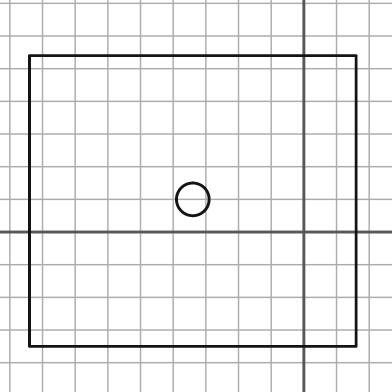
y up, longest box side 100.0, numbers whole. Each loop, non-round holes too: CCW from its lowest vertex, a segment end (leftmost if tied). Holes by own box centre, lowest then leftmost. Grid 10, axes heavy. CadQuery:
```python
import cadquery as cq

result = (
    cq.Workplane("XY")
    .moveTo(-84.0, -35.0)
    .lineTo(16.0, -35.0)
    .lineTo(16.0, 54.0)
    .lineTo(-84.0, 54.0)
    .close()
    .moveTo(-34.0, 10.0)
    .circle(5.0)
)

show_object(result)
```